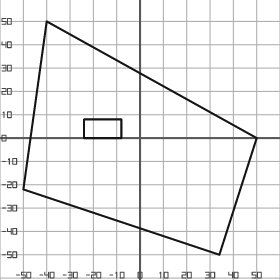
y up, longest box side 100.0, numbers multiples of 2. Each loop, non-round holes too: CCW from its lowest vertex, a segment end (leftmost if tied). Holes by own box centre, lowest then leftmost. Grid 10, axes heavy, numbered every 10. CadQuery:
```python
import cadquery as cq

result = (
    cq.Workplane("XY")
    .moveTo(34.0, -50.0)
    .lineTo(50.0, 0.0)
    .lineTo(-40.0, 50.0)
    .lineTo(-50.0, -22.0)
    .close()
    .moveTo(-24.0, 0.0)
    .lineTo(-8.0, 0.0)
    .lineTo(-8.0, 8.0)
    .lineTo(-24.0, 8.0)
    .close()
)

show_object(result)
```